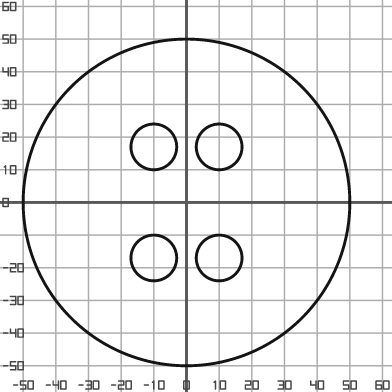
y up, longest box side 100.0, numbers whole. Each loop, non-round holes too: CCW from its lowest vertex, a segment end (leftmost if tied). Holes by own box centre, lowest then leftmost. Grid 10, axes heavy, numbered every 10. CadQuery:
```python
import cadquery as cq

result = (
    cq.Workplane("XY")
    .moveTo(0.0, 0.0)
    .circle(50.0)
    .moveTo(-10.0, -17.0)
    .circle(7.0)
    .moveTo(10.0, -17.0)
    .circle(7.0)
    .moveTo(-10.0, 17.0)
    .circle(7.0)
    .moveTo(10.0, 17.0)
    .circle(7.0)
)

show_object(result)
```